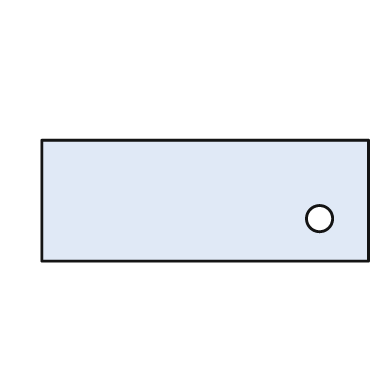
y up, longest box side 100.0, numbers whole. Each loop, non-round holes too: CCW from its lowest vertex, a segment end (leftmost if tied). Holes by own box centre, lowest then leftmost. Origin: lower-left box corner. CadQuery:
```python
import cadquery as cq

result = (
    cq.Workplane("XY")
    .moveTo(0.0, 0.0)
    .lineTo(100.0, 0.0)
    .lineTo(100.0, 37.0)
    .lineTo(0.0, 37.0)
    .close()
    .moveTo(85.0, 13.0)
    .circle(4.0)
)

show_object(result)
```